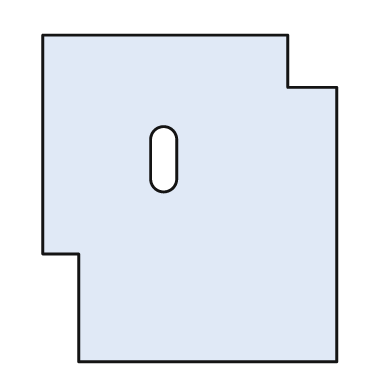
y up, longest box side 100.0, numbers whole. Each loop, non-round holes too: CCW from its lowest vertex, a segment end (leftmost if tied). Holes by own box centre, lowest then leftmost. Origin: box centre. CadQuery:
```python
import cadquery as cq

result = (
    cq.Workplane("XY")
    .moveTo(-34.0, -50.0)
    .lineTo(45.0, -50.0)
    .lineTo(45.0, 34.0)
    .lineTo(30.0, 34.0)
    .lineTo(30.0, 50.0)
    .lineTo(-45.0, 50.0)
    .lineTo(-45.0, -17.0)
    .lineTo(-34.0, -17.0)
    .close()
    .moveTo(-12.0, 6.0)
    .threePointArc((-8.0, 2.0), (-4.0, 6.0))
    .lineTo(-4.0, 18.0)
    .threePointArc((-8.0, 22.0), (-12.0, 18.0))
    .close()
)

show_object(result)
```